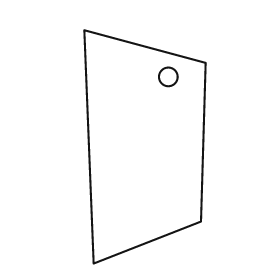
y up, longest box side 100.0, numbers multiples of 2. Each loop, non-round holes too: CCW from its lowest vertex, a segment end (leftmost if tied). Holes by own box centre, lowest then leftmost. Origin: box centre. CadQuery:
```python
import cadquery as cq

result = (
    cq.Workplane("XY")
    .moveTo(-22.0, -50.0)
    .lineTo(24.0, -32.0)
    .lineTo(26.0, 36.0)
    .lineTo(-26.0, 50.0)
    .close()
    .moveTo(10.0, 30.0)
    .circle(4.0)
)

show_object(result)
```